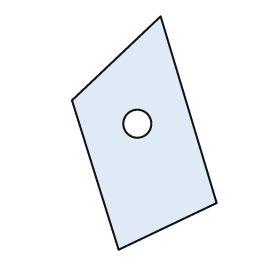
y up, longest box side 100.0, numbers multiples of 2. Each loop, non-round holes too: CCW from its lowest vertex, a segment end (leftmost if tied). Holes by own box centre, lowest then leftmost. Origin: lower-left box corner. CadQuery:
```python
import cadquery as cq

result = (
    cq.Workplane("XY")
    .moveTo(20.0, 0.0)
    .lineTo(62.0, 20.0)
    .lineTo(38.0, 100.0)
    .lineTo(0.0, 64.0)
    .close()
    .moveTo(28.0, 54.0)
    .circle(6.0)
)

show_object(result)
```